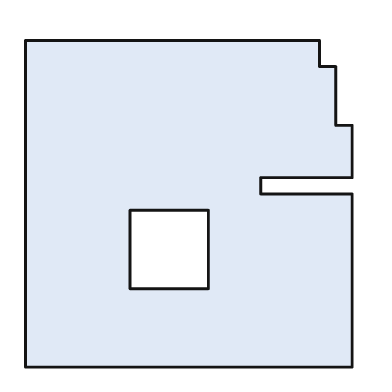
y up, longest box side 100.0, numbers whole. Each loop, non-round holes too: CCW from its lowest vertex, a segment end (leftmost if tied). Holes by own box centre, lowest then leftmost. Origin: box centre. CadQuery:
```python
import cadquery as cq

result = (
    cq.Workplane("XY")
    .moveTo(-50.0, -50.0)
    .lineTo(50.0, -50.0)
    .lineTo(50.0, 3.0)
    .lineTo(22.0, 3.0)
    .lineTo(22.0, 8.0)
    .lineTo(50.0, 8.0)
    .lineTo(50.0, 24.0)
    .lineTo(45.0, 24.0)
    .lineTo(45.0, 42.0)
    .lineTo(40.0, 42.0)
    .lineTo(40.0, 50.0)
    .lineTo(-50.0, 50.0)
    .close()
    .moveTo(-18.0, -26.0)
    .lineTo(6.0, -26.0)
    .lineTo(6.0, -2.0)
    .lineTo(-18.0, -2.0)
    .close()
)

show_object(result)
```